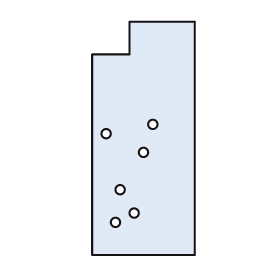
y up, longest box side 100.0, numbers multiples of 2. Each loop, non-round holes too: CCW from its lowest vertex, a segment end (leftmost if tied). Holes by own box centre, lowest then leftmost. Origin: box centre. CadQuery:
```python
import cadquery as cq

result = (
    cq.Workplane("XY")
    .moveTo(-22.0, -50.0)
    .lineTo(22.0, -50.0)
    .lineTo(22.0, 50.0)
    .lineTo(-6.0, 50.0)
    .lineTo(-6.0, 36.0)
    .lineTo(-22.0, 36.0)
    .close()
    .moveTo(-12.0, -36.0)
    .circle(2.0)
    .moveTo(-4.0, -32.0)
    .circle(2.0)
    .moveTo(-10.0, -22.0)
    .circle(2.0)
    .moveTo(0.0, -6.0)
    .circle(2.0)
    .moveTo(-16.0, 2.0)
    .circle(2.0)
    .moveTo(4.0, 6.0)
    .circle(2.0)
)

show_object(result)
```